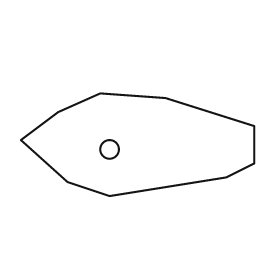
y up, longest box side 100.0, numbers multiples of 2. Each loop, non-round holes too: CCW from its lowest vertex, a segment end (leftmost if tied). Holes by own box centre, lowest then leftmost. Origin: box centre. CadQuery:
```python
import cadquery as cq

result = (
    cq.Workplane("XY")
    .moveTo(-12.0, -22.0)
    .lineTo(38.0, -14.0)
    .lineTo(50.0, -8.0)
    .lineTo(50.0, 8.0)
    .lineTo(12.0, 20.0)
    .lineTo(-16.0, 22.0)
    .lineTo(-34.0, 14.0)
    .lineTo(-50.0, 2.0)
    .lineTo(-30.0, -16.0)
    .close()
    .moveTo(-12.0, -2.0)
    .circle(4.0)
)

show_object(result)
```